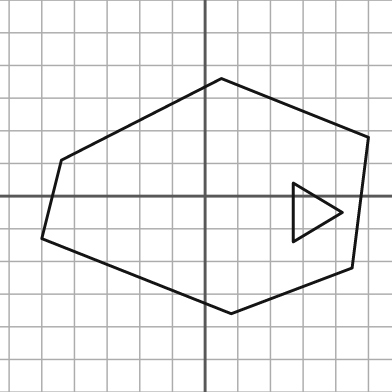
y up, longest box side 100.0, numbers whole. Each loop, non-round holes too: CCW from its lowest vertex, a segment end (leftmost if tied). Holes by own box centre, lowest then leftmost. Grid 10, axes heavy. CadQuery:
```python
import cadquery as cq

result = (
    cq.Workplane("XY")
    .moveTo(8.0, -36.0)
    .lineTo(45.0, -22.0)
    .lineTo(50.0, 18.0)
    .lineTo(5.0, 36.0)
    .lineTo(-44.0, 11.0)
    .lineTo(-50.0, -13.0)
    .close()
    .moveTo(27.0, -14.0)
    .lineTo(42.0, -5.0)
    .lineTo(27.0, 4.0)
    .close()
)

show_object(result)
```